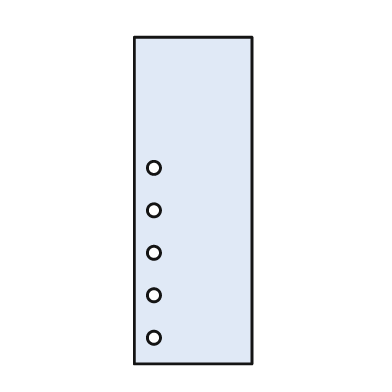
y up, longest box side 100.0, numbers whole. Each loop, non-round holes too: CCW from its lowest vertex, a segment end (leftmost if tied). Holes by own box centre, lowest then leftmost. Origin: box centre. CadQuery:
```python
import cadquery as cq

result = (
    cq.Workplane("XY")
    .moveTo(-18.0, -50.0)
    .lineTo(18.0, -50.0)
    .lineTo(18.0, 50.0)
    .lineTo(-18.0, 50.0)
    .close()
    .moveTo(-12.0, -42.0)
    .circle(2.0)
    .moveTo(-12.0, -29.0)
    .circle(2.0)
    .moveTo(-12.0, -16.0)
    .circle(2.0)
    .moveTo(-12.0, -3.0)
    .circle(2.0)
    .moveTo(-12.0, 10.0)
    .circle(2.0)
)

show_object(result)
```